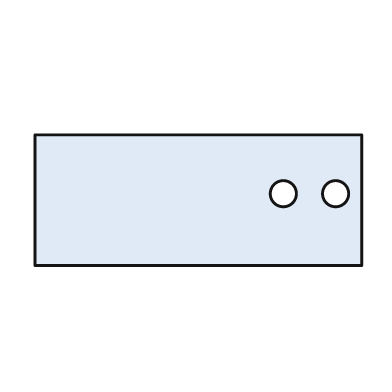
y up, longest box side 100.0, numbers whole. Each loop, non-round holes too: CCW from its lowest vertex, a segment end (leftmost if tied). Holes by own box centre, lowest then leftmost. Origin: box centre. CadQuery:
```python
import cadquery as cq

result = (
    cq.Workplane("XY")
    .moveTo(-50.0, -20.0)
    .lineTo(50.0, -20.0)
    .lineTo(50.0, 20.0)
    .lineTo(-50.0, 20.0)
    .close()
    .moveTo(26.0, 2.0)
    .circle(4.0)
    .moveTo(42.0, 2.0)
    .circle(4.0)
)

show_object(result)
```